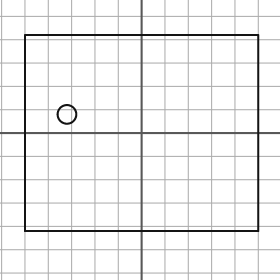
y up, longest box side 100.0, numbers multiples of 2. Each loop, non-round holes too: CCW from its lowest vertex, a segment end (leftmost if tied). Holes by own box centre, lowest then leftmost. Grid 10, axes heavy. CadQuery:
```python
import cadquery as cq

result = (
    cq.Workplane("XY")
    .moveTo(-50.0, -42.0)
    .lineTo(50.0, -42.0)
    .lineTo(50.0, 42.0)
    .lineTo(-50.0, 42.0)
    .close()
    .moveTo(-32.0, 8.0)
    .circle(4.0)
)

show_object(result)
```